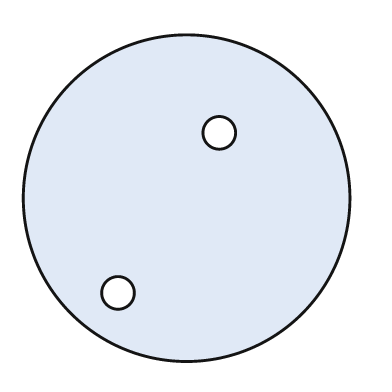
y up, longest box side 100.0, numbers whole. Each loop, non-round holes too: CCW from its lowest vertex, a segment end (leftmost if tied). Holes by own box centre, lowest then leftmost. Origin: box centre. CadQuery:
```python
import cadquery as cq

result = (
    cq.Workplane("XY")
    .moveTo(0.0, 0.0)
    .circle(50.0)
    .moveTo(-21.0, -29.0)
    .circle(5.0)
    .moveTo(10.0, 20.0)
    .circle(5.0)
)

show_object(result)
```